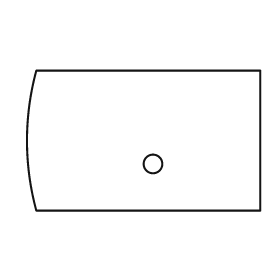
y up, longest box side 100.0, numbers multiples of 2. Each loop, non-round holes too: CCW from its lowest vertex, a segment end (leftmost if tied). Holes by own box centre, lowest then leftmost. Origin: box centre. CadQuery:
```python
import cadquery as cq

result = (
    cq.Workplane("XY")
    .moveTo(-46.0, -30.0)
    .lineTo(50.0, -30.0)
    .lineTo(50.0, 30.0)
    .lineTo(-46.0, 30.0)
    .threePointArc((-50.0, 0.0), (-46.0, -30.0))
    .close()
    .moveTo(4.0, -10.0)
    .circle(4.0)
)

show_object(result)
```